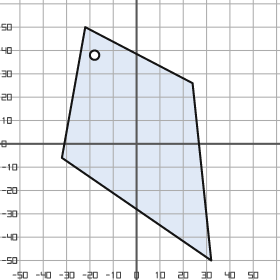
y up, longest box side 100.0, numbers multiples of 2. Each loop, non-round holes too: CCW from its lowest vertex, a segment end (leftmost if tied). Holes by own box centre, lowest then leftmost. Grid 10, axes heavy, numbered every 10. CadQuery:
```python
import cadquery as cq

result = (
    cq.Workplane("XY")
    .moveTo(32.0, -50.0)
    .lineTo(24.0, 26.0)
    .lineTo(-22.0, 50.0)
    .lineTo(-32.0, -6.0)
    .close()
    .moveTo(-18.0, 38.0)
    .circle(2.0)
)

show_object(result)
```